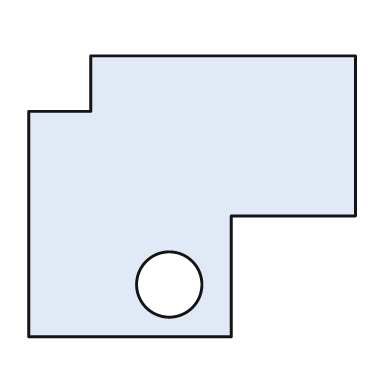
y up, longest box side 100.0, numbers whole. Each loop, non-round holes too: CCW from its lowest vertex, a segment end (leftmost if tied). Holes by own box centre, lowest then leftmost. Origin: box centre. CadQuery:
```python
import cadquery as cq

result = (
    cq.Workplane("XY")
    .moveTo(-50.0, -43.0)
    .lineTo(12.0, -43.0)
    .lineTo(12.0, -6.0)
    .lineTo(50.0, -6.0)
    .lineTo(50.0, 43.0)
    .lineTo(-31.0, 43.0)
    .lineTo(-31.0, 26.0)
    .lineTo(-50.0, 26.0)
    .close()
    .moveTo(-7.0, -27.0)
    .circle(10.0)
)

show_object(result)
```